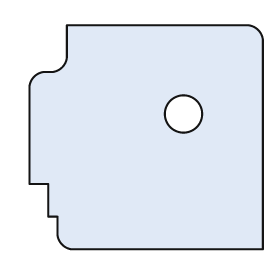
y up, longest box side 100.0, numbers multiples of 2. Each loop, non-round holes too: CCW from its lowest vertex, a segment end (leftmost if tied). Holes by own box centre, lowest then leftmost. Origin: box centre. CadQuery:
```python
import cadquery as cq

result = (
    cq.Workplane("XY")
    .moveTo(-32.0, -48.0)
    .lineTo(50.0, -48.0)
    .lineTo(50.0, 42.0)
    .threePointArc((48.0, 46.0), (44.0, 48.0))
    .lineTo(-34.0, 48.0)
    .lineTo(-34.0, 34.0)
    .threePointArc((-36.0, 30.0), (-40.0, 28.0))
    .lineTo(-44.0, 28.0)
    .threePointArc((-48.0, 26.0), (-50.0, 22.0))
    .lineTo(-50.0, -20.0)
    .lineTo(-42.0, -20.0)
    .lineTo(-42.0, -34.0)
    .lineTo(-38.0, -34.0)
    .lineTo(-38.0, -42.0)
    .threePointArc((-36.0, -46.0), (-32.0, -48.0))
    .close()
    .moveTo(16.0, 10.0)
    .circle(8.0)
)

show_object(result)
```